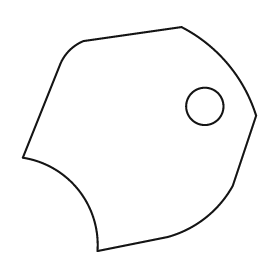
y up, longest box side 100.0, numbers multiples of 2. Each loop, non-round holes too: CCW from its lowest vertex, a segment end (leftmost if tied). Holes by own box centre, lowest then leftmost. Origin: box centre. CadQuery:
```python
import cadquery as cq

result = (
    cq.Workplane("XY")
    .moveTo(-18.0, -48.0)
    .lineTo(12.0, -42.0)
    .threePointArc((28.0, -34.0), (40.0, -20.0))
    .lineTo(50.0, 10.0)
    .threePointArc((38.0, 32.0), (18.0, 48.0))
    .lineTo(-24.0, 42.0)
    .threePointArc((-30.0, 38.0), (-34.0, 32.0))
    .lineTo(-50.0, -8.0)
    .threePointArc((-26.0, -22.0), (-18.0, -48.0))
    .close()
    .moveTo(28.0, 14.0)
    .circle(8.0)
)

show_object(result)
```